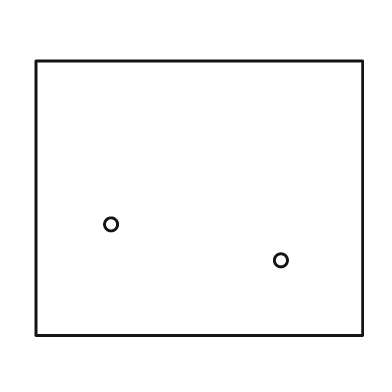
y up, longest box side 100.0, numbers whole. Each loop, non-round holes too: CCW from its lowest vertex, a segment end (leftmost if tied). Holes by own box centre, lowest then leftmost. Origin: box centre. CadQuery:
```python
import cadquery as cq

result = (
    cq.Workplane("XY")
    .moveTo(-50.0, -42.0)
    .lineTo(50.0, -42.0)
    .lineTo(50.0, 42.0)
    .lineTo(-50.0, 42.0)
    .close()
    .moveTo(25.0, -19.0)
    .circle(2.0)
    .moveTo(-27.0, -8.0)
    .circle(2.0)
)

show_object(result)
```